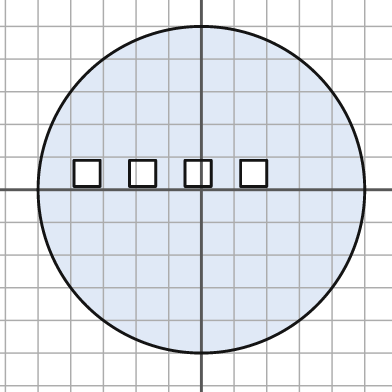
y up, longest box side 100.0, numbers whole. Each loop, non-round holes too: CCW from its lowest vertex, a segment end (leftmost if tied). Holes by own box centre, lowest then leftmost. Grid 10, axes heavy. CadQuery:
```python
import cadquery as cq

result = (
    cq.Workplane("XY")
    .moveTo(0.0, 0.0)
    .circle(50.0)
    .moveTo(-39.0, 1.0)
    .lineTo(-31.0, 1.0)
    .lineTo(-31.0, 9.0)
    .lineTo(-39.0, 9.0)
    .close()
    .moveTo(-22.0, 1.0)
    .lineTo(-14.0, 1.0)
    .lineTo(-14.0, 9.0)
    .lineTo(-22.0, 9.0)
    .close()
    .moveTo(-5.0, 1.0)
    .lineTo(3.0, 1.0)
    .lineTo(3.0, 9.0)
    .lineTo(-5.0, 9.0)
    .close()
    .moveTo(12.0, 1.0)
    .lineTo(20.0, 1.0)
    .lineTo(20.0, 9.0)
    .lineTo(12.0, 9.0)
    .close()
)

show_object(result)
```